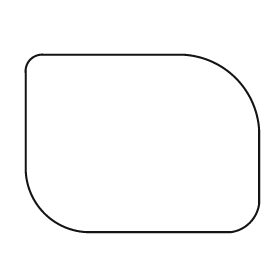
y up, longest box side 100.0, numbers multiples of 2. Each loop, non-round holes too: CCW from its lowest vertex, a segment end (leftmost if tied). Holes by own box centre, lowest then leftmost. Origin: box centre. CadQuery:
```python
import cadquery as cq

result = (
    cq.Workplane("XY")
    .moveTo(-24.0, -38.0)
    .lineTo(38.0, -38.0)
    .threePointArc((46.0, -34.0), (50.0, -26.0))
    .lineTo(50.0, 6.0)
    .threePointArc((40.0, 28.0), (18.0, 38.0))
    .lineTo(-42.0, 38.0)
    .threePointArc((-48.0, 36.0), (-50.0, 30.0))
    .lineTo(-50.0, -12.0)
    .threePointArc((-42.0, -30.0), (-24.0, -38.0))
    .close()
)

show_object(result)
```